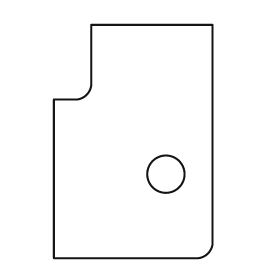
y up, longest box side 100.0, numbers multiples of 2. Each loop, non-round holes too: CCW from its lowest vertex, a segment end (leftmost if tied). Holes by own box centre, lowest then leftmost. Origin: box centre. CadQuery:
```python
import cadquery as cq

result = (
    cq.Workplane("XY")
    .moveTo(-34.0, -50.0)
    .lineTo(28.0, -50.0)
    .threePointArc((32.0, -48.0), (34.0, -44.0))
    .lineTo(34.0, 50.0)
    .lineTo(-18.0, 50.0)
    .lineTo(-18.0, 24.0)
    .threePointArc((-20.0, 20.0), (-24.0, 18.0))
    .lineTo(-34.0, 18.0)
    .close()
    .moveTo(14.0, -14.0)
    .circle(8.0)
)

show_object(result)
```